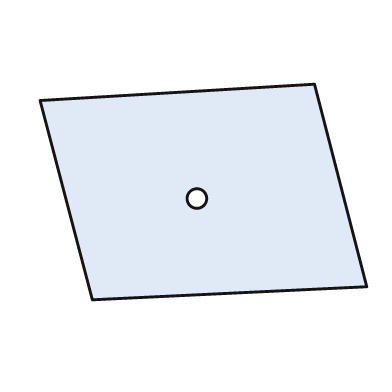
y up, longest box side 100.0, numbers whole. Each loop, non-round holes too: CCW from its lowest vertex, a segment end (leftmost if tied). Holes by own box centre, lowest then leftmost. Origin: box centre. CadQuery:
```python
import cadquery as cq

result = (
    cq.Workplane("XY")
    .moveTo(-34.0, -33.0)
    .lineTo(50.0, -29.0)
    .lineTo(34.0, 33.0)
    .lineTo(-50.0, 28.0)
    .close()
    .moveTo(-2.0, -2.0)
    .circle(3.0)
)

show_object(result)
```